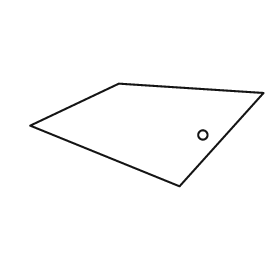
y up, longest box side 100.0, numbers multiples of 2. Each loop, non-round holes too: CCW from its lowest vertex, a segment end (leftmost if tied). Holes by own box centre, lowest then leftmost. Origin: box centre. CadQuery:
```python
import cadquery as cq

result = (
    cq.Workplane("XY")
    .moveTo(14.0, -22.0)
    .lineTo(50.0, 18.0)
    .lineTo(-12.0, 22.0)
    .lineTo(-50.0, 4.0)
    .close()
    .moveTo(24.0, 0.0)
    .circle(2.0)
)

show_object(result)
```